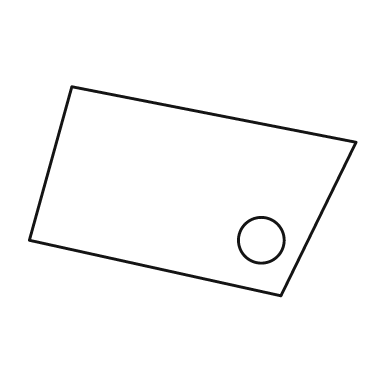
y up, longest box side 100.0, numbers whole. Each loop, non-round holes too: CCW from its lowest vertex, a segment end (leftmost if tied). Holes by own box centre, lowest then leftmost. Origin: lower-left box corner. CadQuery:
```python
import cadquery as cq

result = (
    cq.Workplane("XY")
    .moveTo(77.0, 0.0)
    .lineTo(100.0, 47.0)
    .lineTo(13.0, 64.0)
    .lineTo(0.0, 17.0)
    .close()
    .moveTo(71.0, 17.0)
    .circle(7.0)
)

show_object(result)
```